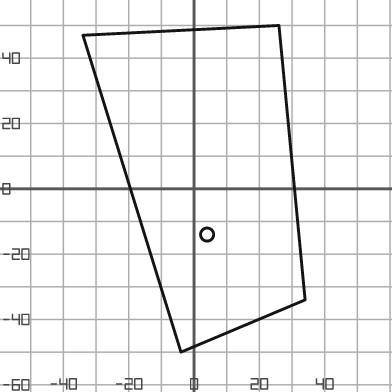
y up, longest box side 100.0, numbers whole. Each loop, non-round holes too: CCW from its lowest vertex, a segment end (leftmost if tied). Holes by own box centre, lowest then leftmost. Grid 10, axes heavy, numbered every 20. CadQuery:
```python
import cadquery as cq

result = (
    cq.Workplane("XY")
    .moveTo(-4.0, -50.0)
    .lineTo(34.0, -34.0)
    .lineTo(26.0, 50.0)
    .lineTo(-34.0, 47.0)
    .close()
    .moveTo(4.0, -14.0)
    .circle(2.0)
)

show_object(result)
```